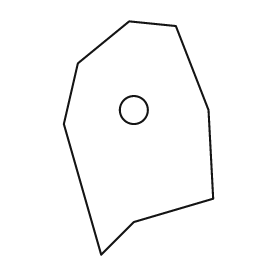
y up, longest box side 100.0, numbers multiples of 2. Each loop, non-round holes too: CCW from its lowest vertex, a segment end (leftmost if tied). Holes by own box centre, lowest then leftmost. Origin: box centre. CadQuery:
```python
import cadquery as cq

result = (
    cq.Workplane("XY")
    .moveTo(-16.0, -50.0)
    .lineTo(-2.0, -36.0)
    .lineTo(32.0, -26.0)
    .lineTo(30.0, 12.0)
    .lineTo(16.0, 48.0)
    .lineTo(-4.0, 50.0)
    .lineTo(-26.0, 32.0)
    .lineTo(-32.0, 6.0)
    .close()
    .moveTo(-2.0, 12.0)
    .circle(6.0)
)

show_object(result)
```